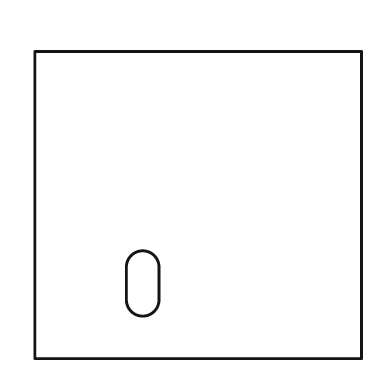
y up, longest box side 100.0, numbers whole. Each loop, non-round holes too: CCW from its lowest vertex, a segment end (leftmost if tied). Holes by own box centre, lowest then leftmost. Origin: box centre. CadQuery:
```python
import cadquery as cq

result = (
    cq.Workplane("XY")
    .moveTo(-50.0, -47.0)
    .lineTo(50.0, -47.0)
    .lineTo(50.0, 47.0)
    .lineTo(-50.0, 47.0)
    .close()
    .moveTo(-22.0, -29.0)
    .threePointArc((-17.0, -34.0), (-12.0, -29.0))
    .lineTo(-12.0, -19.0)
    .threePointArc((-17.0, -14.0), (-22.0, -19.0))
    .close()
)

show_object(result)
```